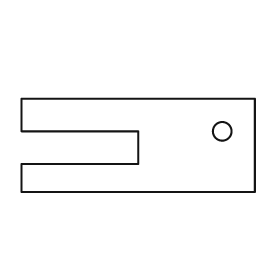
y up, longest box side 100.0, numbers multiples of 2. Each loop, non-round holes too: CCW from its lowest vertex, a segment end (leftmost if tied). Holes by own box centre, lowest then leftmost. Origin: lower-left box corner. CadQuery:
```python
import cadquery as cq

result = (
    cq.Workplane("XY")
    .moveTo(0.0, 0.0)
    .lineTo(100.0, 0.0)
    .lineTo(100.0, 40.0)
    .lineTo(0.0, 40.0)
    .lineTo(0.0, 26.0)
    .lineTo(50.0, 26.0)
    .lineTo(50.0, 12.0)
    .lineTo(0.0, 12.0)
    .close()
    .moveTo(86.0, 26.0)
    .circle(4.0)
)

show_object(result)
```